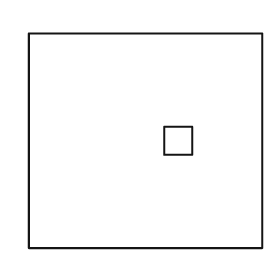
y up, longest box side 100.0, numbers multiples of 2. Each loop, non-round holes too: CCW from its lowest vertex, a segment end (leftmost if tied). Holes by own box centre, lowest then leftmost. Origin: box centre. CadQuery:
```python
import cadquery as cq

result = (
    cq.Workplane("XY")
    .moveTo(-50.0, -46.0)
    .lineTo(50.0, -46.0)
    .lineTo(50.0, 46.0)
    .lineTo(-50.0, 46.0)
    .close()
    .moveTo(8.0, -6.0)
    .lineTo(20.0, -6.0)
    .lineTo(20.0, 6.0)
    .lineTo(8.0, 6.0)
    .close()
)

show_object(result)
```